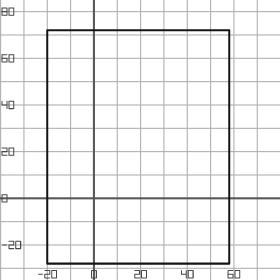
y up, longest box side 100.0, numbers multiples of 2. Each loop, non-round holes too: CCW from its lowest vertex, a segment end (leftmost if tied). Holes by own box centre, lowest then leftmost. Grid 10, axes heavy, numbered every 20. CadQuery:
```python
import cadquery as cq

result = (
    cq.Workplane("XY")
    .moveTo(-20.0, -28.0)
    .lineTo(58.0, -28.0)
    .lineTo(58.0, 72.0)
    .lineTo(-20.0, 72.0)
    .close()
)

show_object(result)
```